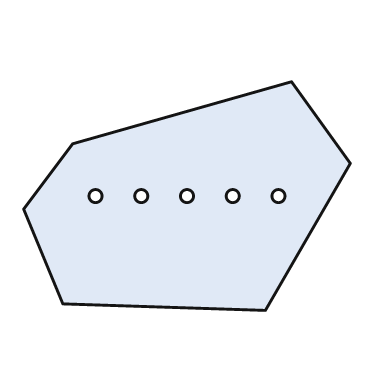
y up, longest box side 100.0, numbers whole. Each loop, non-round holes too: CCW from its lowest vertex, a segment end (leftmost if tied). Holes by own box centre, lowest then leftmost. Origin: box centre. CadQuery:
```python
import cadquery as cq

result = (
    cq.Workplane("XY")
    .moveTo(24.0, -35.0)
    .lineTo(50.0, 10.0)
    .lineTo(32.0, 35.0)
    .lineTo(-35.0, 16.0)
    .lineTo(-50.0, -4.0)
    .lineTo(-38.0, -33.0)
    .close()
    .moveTo(-28.0, 0.0)
    .circle(2.0)
    .moveTo(-14.0, 0.0)
    .circle(2.0)
    .moveTo(0.0, 0.0)
    .circle(2.0)
    .moveTo(14.0, 0.0)
    .circle(2.0)
    .moveTo(28.0, 0.0)
    .circle(2.0)
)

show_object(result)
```